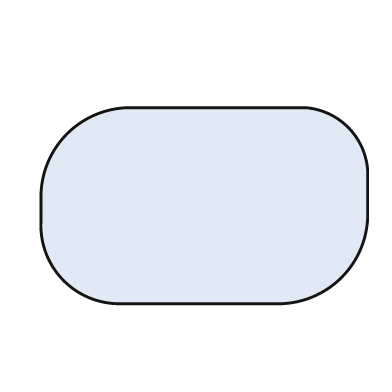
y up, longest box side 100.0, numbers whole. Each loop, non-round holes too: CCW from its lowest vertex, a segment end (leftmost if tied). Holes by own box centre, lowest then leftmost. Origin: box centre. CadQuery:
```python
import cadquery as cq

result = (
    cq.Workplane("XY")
    .moveTo(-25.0, -30.0)
    .lineTo(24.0, -30.0)
    .threePointArc((42.0, -22.0), (50.0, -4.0))
    .lineTo(50.0, 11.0)
    .threePointArc((44.0, 24.0), (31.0, 30.0))
    .lineTo(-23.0, 30.0)
    .threePointArc((-42.0, 22.0), (-50.0, 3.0))
    .lineTo(-50.0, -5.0)
    .threePointArc((-43.0, -23.0), (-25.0, -30.0))
    .close()
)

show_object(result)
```